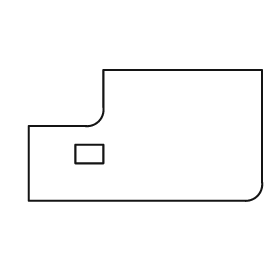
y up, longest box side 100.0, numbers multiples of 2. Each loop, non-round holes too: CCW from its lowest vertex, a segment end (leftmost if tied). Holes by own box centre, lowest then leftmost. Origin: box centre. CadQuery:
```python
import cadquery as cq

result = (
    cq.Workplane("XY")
    .moveTo(-50.0, -28.0)
    .lineTo(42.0, -28.0)
    .threePointArc((48.0, -26.0), (50.0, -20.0))
    .lineTo(50.0, 28.0)
    .lineTo(-18.0, 28.0)
    .lineTo(-18.0, 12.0)
    .threePointArc((-20.0, 6.0), (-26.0, 4.0))
    .lineTo(-50.0, 4.0)
    .close()
    .moveTo(-30.0, -12.0)
    .lineTo(-18.0, -12.0)
    .lineTo(-18.0, -4.0)
    .lineTo(-30.0, -4.0)
    .close()
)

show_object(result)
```